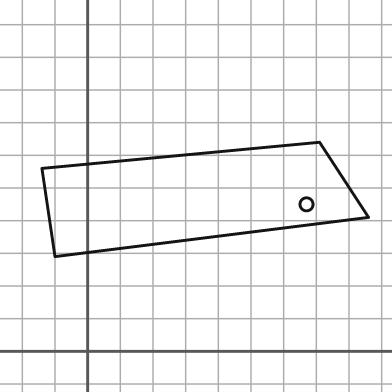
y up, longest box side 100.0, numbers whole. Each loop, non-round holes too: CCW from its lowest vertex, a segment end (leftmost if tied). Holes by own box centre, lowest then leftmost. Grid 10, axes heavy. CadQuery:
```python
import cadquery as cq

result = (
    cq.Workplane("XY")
    .moveTo(-10.0, 29.0)
    .lineTo(86.0, 41.0)
    .lineTo(71.0, 64.0)
    .lineTo(-14.0, 56.0)
    .close()
    .moveTo(67.0, 45.0)
    .circle(2.0)
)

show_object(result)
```